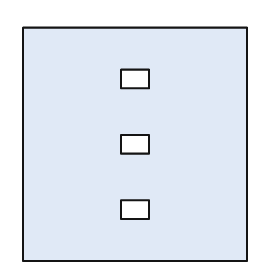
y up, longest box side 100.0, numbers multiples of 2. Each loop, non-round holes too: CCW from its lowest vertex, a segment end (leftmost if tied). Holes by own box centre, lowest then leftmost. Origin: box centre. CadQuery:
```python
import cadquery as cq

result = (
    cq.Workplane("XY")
    .moveTo(-48.0, -50.0)
    .lineTo(48.0, -50.0)
    .lineTo(48.0, 50.0)
    .lineTo(-48.0, 50.0)
    .close()
    .moveTo(-6.0, -32.0)
    .lineTo(6.0, -32.0)
    .lineTo(6.0, -24.0)
    .lineTo(-6.0, -24.0)
    .close()
    .moveTo(-6.0, -4.0)
    .lineTo(6.0, -4.0)
    .lineTo(6.0, 4.0)
    .lineTo(-6.0, 4.0)
    .close()
    .moveTo(-6.0, 24.0)
    .lineTo(6.0, 24.0)
    .lineTo(6.0, 32.0)
    .lineTo(-6.0, 32.0)
    .close()
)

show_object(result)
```